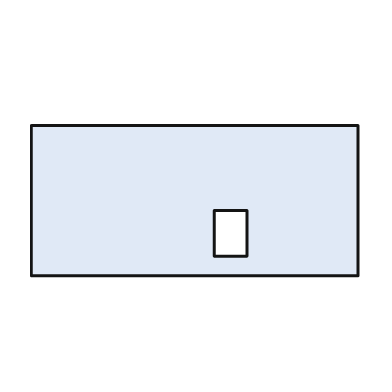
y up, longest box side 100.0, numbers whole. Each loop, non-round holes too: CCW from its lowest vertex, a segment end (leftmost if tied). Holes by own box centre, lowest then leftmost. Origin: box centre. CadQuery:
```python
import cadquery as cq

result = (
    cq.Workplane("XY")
    .moveTo(-50.0, -23.0)
    .lineTo(50.0, -23.0)
    .lineTo(50.0, 23.0)
    .lineTo(-50.0, 23.0)
    .close()
    .moveTo(6.0, -17.0)
    .lineTo(16.0, -17.0)
    .lineTo(16.0, -3.0)
    .lineTo(6.0, -3.0)
    .close()
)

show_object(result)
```